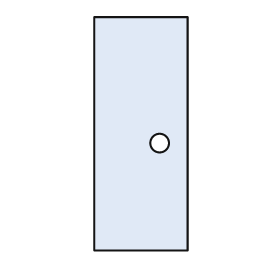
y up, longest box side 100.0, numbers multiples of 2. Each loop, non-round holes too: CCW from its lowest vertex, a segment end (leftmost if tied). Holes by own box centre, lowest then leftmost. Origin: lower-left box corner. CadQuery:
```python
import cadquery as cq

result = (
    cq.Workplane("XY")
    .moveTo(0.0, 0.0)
    .lineTo(40.0, 0.0)
    .lineTo(40.0, 100.0)
    .lineTo(0.0, 100.0)
    .close()
    .moveTo(28.0, 46.0)
    .circle(4.0)
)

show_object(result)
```